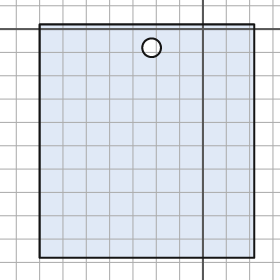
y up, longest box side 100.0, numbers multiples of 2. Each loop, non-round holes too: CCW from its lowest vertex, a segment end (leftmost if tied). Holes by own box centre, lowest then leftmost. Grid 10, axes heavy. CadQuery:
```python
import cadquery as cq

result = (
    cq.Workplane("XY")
    .moveTo(-70.0, -98.0)
    .lineTo(22.0, -98.0)
    .lineTo(22.0, 2.0)
    .lineTo(-70.0, 2.0)
    .close()
    .moveTo(-22.0, -8.0)
    .circle(4.0)
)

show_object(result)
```